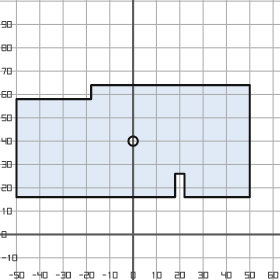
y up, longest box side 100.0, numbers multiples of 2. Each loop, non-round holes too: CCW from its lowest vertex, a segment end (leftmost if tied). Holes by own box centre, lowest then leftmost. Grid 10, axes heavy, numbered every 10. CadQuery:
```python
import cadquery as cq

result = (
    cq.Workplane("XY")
    .moveTo(-50.0, 16.0)
    .lineTo(18.0, 16.0)
    .lineTo(18.0, 26.0)
    .lineTo(22.0, 26.0)
    .lineTo(22.0, 16.0)
    .lineTo(50.0, 16.0)
    .lineTo(50.0, 64.0)
    .lineTo(-18.0, 64.0)
    .lineTo(-18.0, 58.0)
    .lineTo(-50.0, 58.0)
    .close()
    .moveTo(0.0, 40.0)
    .circle(2.0)
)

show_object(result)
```